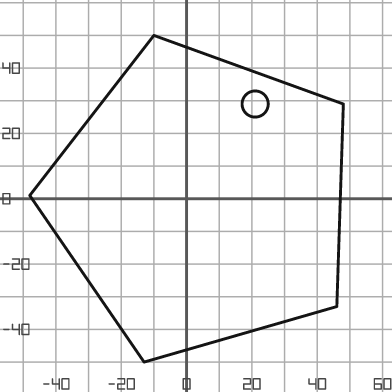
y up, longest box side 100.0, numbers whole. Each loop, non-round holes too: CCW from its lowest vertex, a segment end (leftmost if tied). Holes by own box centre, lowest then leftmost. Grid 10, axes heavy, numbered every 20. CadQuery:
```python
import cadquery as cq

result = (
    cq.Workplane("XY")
    .moveTo(-13.0, -50.0)
    .lineTo(46.0, -33.0)
    .lineTo(48.0, 29.0)
    .lineTo(-10.0, 50.0)
    .lineTo(-48.0, 1.0)
    .close()
    .moveTo(21.0, 29.0)
    .circle(4.0)
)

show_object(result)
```